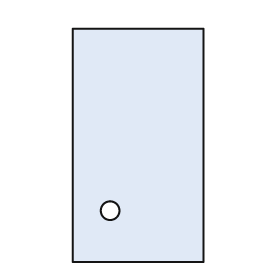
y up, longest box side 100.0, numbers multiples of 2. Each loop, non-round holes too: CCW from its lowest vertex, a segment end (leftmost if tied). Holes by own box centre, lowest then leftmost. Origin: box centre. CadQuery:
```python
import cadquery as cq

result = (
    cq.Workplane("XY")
    .moveTo(-28.0, -50.0)
    .lineTo(28.0, -50.0)
    .lineTo(28.0, 50.0)
    .lineTo(-28.0, 50.0)
    .close()
    .moveTo(-12.0, -28.0)
    .circle(4.0)
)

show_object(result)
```